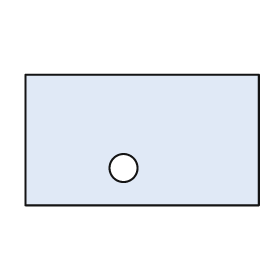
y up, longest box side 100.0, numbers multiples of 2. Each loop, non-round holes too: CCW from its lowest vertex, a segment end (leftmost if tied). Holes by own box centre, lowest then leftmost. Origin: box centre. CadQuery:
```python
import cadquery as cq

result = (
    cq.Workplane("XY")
    .moveTo(-50.0, -28.0)
    .lineTo(50.0, -28.0)
    .lineTo(50.0, 28.0)
    .lineTo(-50.0, 28.0)
    .close()
    .moveTo(-8.0, -12.0)
    .circle(6.0)
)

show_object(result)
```